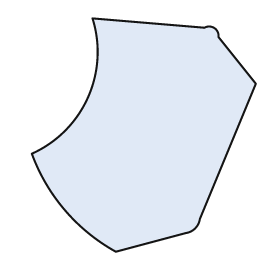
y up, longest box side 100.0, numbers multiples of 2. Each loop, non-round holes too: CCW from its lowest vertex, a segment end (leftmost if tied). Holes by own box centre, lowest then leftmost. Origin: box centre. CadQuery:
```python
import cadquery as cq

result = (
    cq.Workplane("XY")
    .moveTo(-12.0, -50.0)
    .lineTo(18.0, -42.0)
    .threePointArc((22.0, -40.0), (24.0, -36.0))
    .lineTo(48.0, 22.0)
    .lineTo(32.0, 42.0)
    .threePointArc((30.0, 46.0), (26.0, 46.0))
    .lineTo(-22.0, 50.0)
    .threePointArc((-24.0, 16.0), (-48.0, -8.0))
    .threePointArc((-34.0, -32.0), (-12.0, -50.0))
    .close()
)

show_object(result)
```